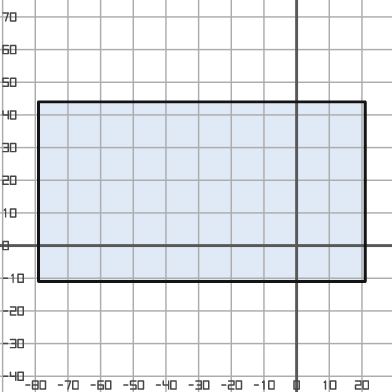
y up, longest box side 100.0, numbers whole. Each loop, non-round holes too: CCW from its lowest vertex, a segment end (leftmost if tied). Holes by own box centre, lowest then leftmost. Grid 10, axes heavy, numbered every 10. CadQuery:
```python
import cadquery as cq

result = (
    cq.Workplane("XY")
    .moveTo(-79.0, -11.0)
    .lineTo(21.0, -11.0)
    .lineTo(21.0, 44.0)
    .lineTo(-79.0, 44.0)
    .close()
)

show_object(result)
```